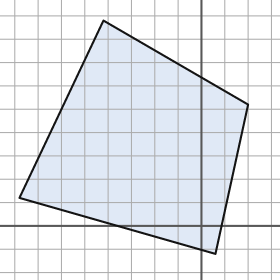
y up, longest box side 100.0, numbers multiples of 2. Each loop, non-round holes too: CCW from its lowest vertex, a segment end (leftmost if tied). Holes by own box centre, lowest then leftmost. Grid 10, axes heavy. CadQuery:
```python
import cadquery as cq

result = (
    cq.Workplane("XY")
    .moveTo(6.0, -12.0)
    .lineTo(20.0, 52.0)
    .lineTo(-42.0, 88.0)
    .lineTo(-78.0, 12.0)
    .close()
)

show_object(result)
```